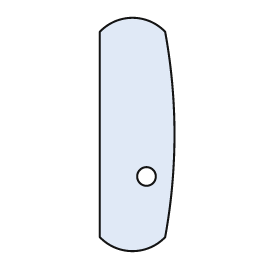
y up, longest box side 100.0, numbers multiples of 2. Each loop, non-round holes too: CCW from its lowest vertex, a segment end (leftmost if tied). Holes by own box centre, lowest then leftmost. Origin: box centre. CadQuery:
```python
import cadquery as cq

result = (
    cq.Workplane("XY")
    .moveTo(-16.0, -44.0)
    .threePointArc((-2.0, -50.0), (12.0, -44.0))
    .threePointArc((16.0, 0.0), (12.0, 44.0))
    .threePointArc((-2.0, 50.0), (-16.0, 44.0))
    .close()
    .moveTo(4.0, -18.0)
    .circle(4.0)
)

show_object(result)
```